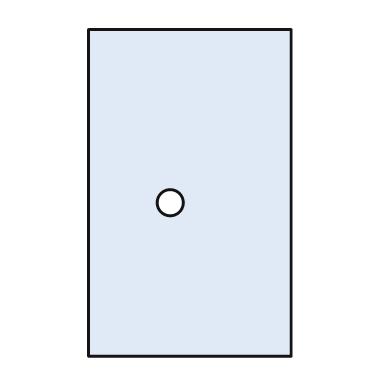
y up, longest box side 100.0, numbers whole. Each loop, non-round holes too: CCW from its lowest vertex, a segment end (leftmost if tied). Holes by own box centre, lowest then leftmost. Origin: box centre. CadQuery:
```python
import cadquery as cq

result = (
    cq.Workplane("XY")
    .moveTo(-31.0, -50.0)
    .lineTo(31.0, -50.0)
    .lineTo(31.0, 50.0)
    .lineTo(-31.0, 50.0)
    .close()
    .moveTo(-6.0, -3.0)
    .circle(4.0)
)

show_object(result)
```